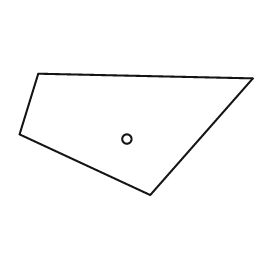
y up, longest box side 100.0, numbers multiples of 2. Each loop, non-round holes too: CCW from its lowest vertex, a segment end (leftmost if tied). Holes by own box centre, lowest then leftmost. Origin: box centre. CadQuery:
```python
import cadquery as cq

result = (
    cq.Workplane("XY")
    .moveTo(6.0, -26.0)
    .lineTo(50.0, 24.0)
    .lineTo(-42.0, 26.0)
    .lineTo(-50.0, 0.0)
    .close()
    .moveTo(-4.0, -2.0)
    .circle(2.0)
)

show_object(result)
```